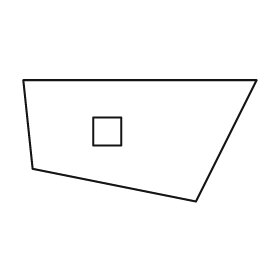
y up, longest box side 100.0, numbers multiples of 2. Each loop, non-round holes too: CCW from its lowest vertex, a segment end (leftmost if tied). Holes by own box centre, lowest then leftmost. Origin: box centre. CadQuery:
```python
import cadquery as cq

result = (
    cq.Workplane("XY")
    .moveTo(24.0, -26.0)
    .lineTo(50.0, 26.0)
    .lineTo(-50.0, 26.0)
    .lineTo(-46.0, -12.0)
    .close()
    .moveTo(-20.0, -2.0)
    .lineTo(-8.0, -2.0)
    .lineTo(-8.0, 10.0)
    .lineTo(-20.0, 10.0)
    .close()
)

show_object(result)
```